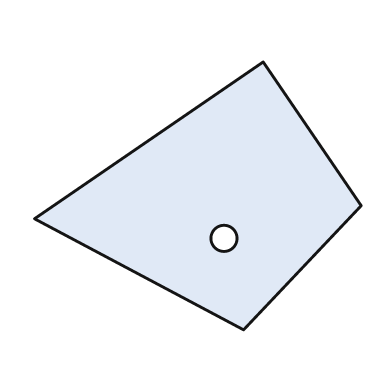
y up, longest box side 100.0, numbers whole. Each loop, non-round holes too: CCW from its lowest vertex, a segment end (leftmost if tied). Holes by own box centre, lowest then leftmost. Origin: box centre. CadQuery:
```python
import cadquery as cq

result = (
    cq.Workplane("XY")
    .moveTo(14.0, -41.0)
    .lineTo(50.0, -3.0)
    .lineTo(20.0, 41.0)
    .lineTo(-50.0, -7.0)
    .close()
    .moveTo(8.0, -13.0)
    .circle(4.0)
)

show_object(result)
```